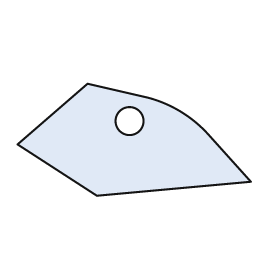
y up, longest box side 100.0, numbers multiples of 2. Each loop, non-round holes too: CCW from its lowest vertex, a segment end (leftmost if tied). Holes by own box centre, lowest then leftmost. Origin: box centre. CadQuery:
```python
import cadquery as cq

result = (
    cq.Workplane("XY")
    .moveTo(-16.0, -24.0)
    .lineTo(50.0, -18.0)
    .lineTo(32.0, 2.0)
    .threePointArc((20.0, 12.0), (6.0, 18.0))
    .lineTo(-20.0, 24.0)
    .lineTo(-50.0, -2.0)
    .close()
    .moveTo(-2.0, 8.0)
    .circle(6.0)
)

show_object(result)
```